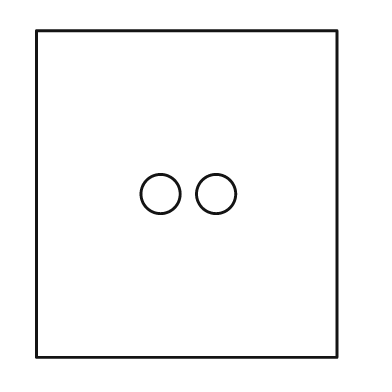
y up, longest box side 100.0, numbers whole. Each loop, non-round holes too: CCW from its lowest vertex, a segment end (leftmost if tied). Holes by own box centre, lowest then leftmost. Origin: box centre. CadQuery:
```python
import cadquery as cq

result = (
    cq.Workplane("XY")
    .moveTo(-46.0, -50.0)
    .lineTo(46.0, -50.0)
    .lineTo(46.0, 50.0)
    .lineTo(-46.0, 50.0)
    .close()
    .moveTo(-8.0, 0.0)
    .circle(6.0)
    .moveTo(9.0, 0.0)
    .circle(6.0)
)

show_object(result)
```